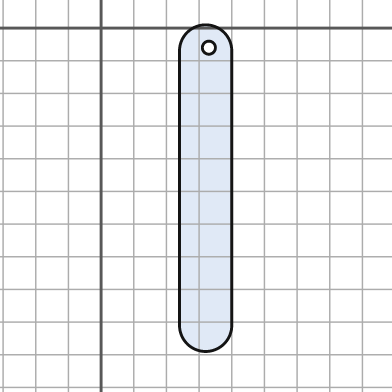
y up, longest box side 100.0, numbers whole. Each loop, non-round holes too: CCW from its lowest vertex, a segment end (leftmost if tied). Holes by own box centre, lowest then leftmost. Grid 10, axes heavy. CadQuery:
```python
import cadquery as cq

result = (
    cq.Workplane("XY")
    .moveTo(24.0, -91.0)
    .threePointArc((32.0, -99.0), (40.0, -91.0))
    .lineTo(40.0, -7.0)
    .threePointArc((32.0, 1.0), (24.0, -7.0))
    .close()
    .moveTo(33.0, -6.0)
    .circle(2.0)
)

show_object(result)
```